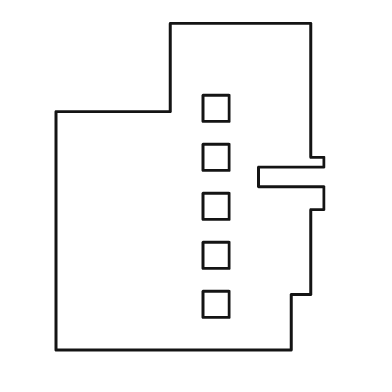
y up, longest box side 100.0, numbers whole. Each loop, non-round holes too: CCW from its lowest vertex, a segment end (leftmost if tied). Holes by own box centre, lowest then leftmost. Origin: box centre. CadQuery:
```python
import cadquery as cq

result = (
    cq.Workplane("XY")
    .moveTo(-41.0, -50.0)
    .lineTo(31.0, -50.0)
    .lineTo(31.0, -33.0)
    .lineTo(37.0, -33.0)
    .lineTo(37.0, -7.0)
    .lineTo(41.0, -7.0)
    .lineTo(41.0, 0.0)
    .lineTo(21.0, 0.0)
    .lineTo(21.0, 6.0)
    .lineTo(41.0, 6.0)
    .lineTo(41.0, 9.0)
    .lineTo(37.0, 9.0)
    .lineTo(37.0, 50.0)
    .lineTo(-6.0, 50.0)
    .lineTo(-6.0, 23.0)
    .lineTo(-41.0, 23.0)
    .close()
    .moveTo(4.0, -40.0)
    .lineTo(12.0, -40.0)
    .lineTo(12.0, -32.0)
    .lineTo(4.0, -32.0)
    .close()
    .moveTo(4.0, -25.0)
    .lineTo(12.0, -25.0)
    .lineTo(12.0, -17.0)
    .lineTo(4.0, -17.0)
    .close()
    .moveTo(4.0, -10.0)
    .lineTo(12.0, -10.0)
    .lineTo(12.0, -2.0)
    .lineTo(4.0, -2.0)
    .close()
    .moveTo(4.0, 5.0)
    .lineTo(12.0, 5.0)
    .lineTo(12.0, 13.0)
    .lineTo(4.0, 13.0)
    .close()
    .moveTo(4.0, 20.0)
    .lineTo(12.0, 20.0)
    .lineTo(12.0, 28.0)
    .lineTo(4.0, 28.0)
    .close()
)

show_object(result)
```